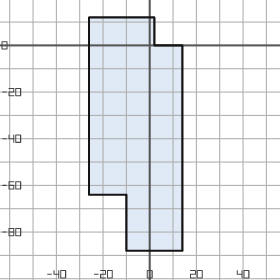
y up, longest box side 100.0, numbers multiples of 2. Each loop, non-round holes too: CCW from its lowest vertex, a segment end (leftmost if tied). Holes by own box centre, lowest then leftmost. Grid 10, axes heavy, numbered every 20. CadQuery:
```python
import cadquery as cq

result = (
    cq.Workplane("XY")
    .moveTo(-10.0, -88.0)
    .lineTo(14.0, -88.0)
    .lineTo(14.0, 0.0)
    .lineTo(2.0, 0.0)
    .lineTo(2.0, 12.0)
    .lineTo(-26.0, 12.0)
    .lineTo(-26.0, -64.0)
    .lineTo(-10.0, -64.0)
    .close()
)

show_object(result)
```